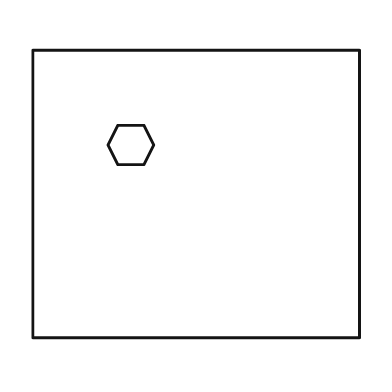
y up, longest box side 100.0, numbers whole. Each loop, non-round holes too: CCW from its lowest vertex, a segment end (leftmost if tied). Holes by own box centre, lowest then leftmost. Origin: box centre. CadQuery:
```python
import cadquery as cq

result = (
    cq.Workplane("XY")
    .moveTo(-50.0, -44.0)
    .lineTo(50.0, -44.0)
    .lineTo(50.0, 44.0)
    .lineTo(-50.0, 44.0)
    .close()
    .moveTo(-24.0, 9.0)
    .lineTo(-16.0, 9.0)
    .lineTo(-13.0, 15.0)
    .lineTo(-16.0, 21.0)
    .lineTo(-24.0, 21.0)
    .lineTo(-27.0, 15.0)
    .close()
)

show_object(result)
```